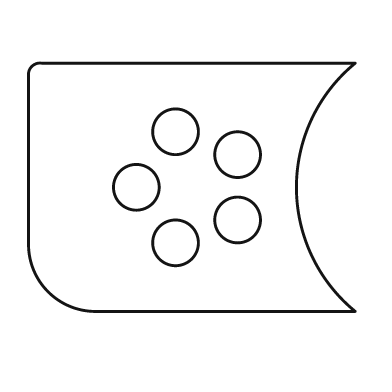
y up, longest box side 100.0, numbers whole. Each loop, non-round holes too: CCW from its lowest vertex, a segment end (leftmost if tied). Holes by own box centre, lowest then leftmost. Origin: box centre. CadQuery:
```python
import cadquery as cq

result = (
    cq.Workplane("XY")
    .moveTo(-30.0, -38.0)
    .lineTo(50.0, -38.0)
    .threePointArc((32.0, 0.0), (50.0, 38.0))
    .lineTo(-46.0, 38.0)
    .threePointArc((-49.0, 37.0), (-50.0, 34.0))
    .lineTo(-50.0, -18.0)
    .threePointArc((-44.0, -32.0), (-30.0, -38.0))
    .close()
    .moveTo(-5.0, -17.0)
    .circle(7.0)
    .moveTo(14.0, -10.0)
    .circle(7.0)
    .moveTo(-17.0, 0.0)
    .circle(7.0)
    .moveTo(14.0, 10.0)
    .circle(7.0)
    .moveTo(-5.0, 17.0)
    .circle(7.0)
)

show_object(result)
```